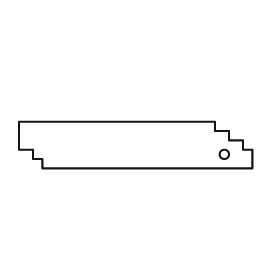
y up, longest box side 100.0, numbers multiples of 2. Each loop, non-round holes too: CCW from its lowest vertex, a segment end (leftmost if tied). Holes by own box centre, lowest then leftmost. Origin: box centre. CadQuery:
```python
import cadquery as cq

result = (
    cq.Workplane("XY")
    .moveTo(-40.0, -10.0)
    .lineTo(50.0, -10.0)
    .lineTo(50.0, -2.0)
    .lineTo(46.0, -2.0)
    .lineTo(46.0, 2.0)
    .lineTo(40.0, 2.0)
    .lineTo(40.0, 6.0)
    .lineTo(34.0, 6.0)
    .lineTo(34.0, 10.0)
    .lineTo(-50.0, 10.0)
    .lineTo(-50.0, -2.0)
    .lineTo(-44.0, -2.0)
    .lineTo(-44.0, -6.0)
    .lineTo(-40.0, -6.0)
    .close()
    .moveTo(38.0, -4.0)
    .circle(2.0)
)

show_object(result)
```